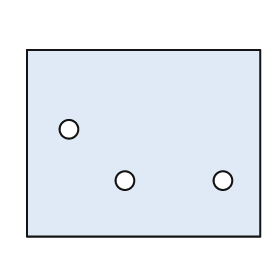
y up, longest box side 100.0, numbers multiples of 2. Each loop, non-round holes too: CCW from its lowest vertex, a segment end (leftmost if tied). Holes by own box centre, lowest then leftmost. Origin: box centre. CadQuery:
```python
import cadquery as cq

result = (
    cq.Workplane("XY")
    .moveTo(-50.0, -40.0)
    .lineTo(50.0, -40.0)
    .lineTo(50.0, 40.0)
    .lineTo(-50.0, 40.0)
    .close()
    .moveTo(-8.0, -16.0)
    .circle(4.0)
    .moveTo(34.0, -16.0)
    .circle(4.0)
    .moveTo(-32.0, 6.0)
    .circle(4.0)
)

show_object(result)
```